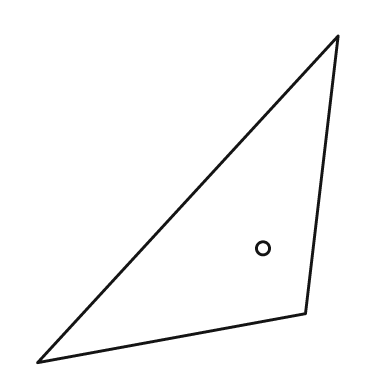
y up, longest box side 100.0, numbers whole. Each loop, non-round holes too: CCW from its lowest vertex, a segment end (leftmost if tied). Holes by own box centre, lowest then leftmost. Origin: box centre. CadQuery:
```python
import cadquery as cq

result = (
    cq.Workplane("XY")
    .moveTo(-46.0, -50.0)
    .lineTo(36.0, -35.0)
    .lineTo(46.0, 50.0)
    .close()
    .moveTo(23.0, -15.0)
    .circle(2.0)
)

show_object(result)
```